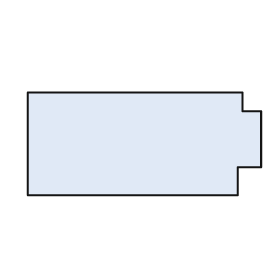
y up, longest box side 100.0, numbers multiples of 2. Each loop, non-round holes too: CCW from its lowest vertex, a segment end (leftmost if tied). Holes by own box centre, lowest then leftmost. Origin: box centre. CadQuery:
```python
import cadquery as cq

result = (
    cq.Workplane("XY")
    .moveTo(-50.0, -22.0)
    .lineTo(40.0, -22.0)
    .lineTo(40.0, -10.0)
    .lineTo(50.0, -10.0)
    .lineTo(50.0, 14.0)
    .lineTo(42.0, 14.0)
    .lineTo(42.0, 22.0)
    .lineTo(-50.0, 22.0)
    .close()
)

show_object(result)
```